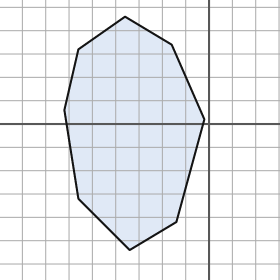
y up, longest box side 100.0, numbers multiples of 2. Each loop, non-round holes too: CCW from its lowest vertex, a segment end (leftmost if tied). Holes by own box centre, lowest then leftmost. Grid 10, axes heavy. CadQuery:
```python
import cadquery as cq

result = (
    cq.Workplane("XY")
    .moveTo(-34.0, -54.0)
    .lineTo(-14.0, -42.0)
    .lineTo(-2.0, 2.0)
    .lineTo(-16.0, 34.0)
    .lineTo(-36.0, 46.0)
    .lineTo(-56.0, 32.0)
    .lineTo(-62.0, 6.0)
    .lineTo(-56.0, -32.0)
    .close()
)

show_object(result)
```